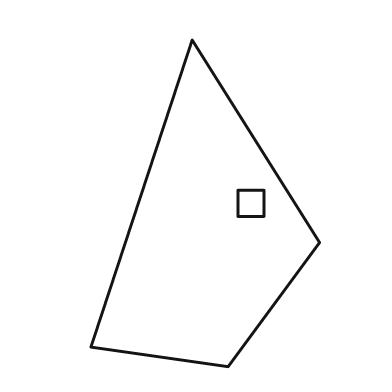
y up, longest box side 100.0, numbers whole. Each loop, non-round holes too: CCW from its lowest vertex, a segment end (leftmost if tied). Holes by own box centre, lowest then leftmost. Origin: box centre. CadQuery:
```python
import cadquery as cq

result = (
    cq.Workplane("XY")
    .moveTo(7.0, -50.0)
    .lineTo(35.0, -12.0)
    .lineTo(-4.0, 50.0)
    .lineTo(-35.0, -44.0)
    .close()
    .moveTo(10.0, -4.0)
    .lineTo(18.0, -4.0)
    .lineTo(18.0, 4.0)
    .lineTo(10.0, 4.0)
    .close()
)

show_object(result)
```